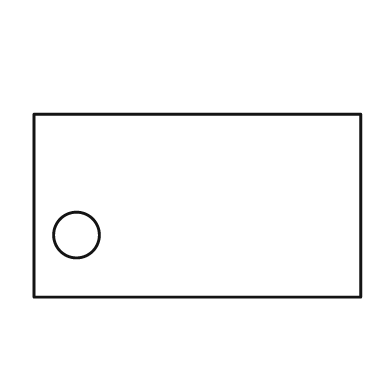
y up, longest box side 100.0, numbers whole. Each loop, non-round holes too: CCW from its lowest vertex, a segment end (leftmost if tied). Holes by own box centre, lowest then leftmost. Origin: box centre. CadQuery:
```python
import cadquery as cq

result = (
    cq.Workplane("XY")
    .moveTo(-50.0, -28.0)
    .lineTo(50.0, -28.0)
    .lineTo(50.0, 28.0)
    .lineTo(-50.0, 28.0)
    .close()
    .moveTo(-37.0, -9.0)
    .circle(7.0)
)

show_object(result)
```